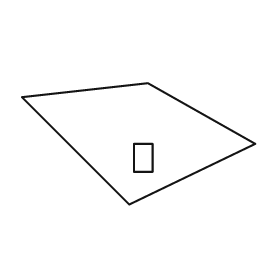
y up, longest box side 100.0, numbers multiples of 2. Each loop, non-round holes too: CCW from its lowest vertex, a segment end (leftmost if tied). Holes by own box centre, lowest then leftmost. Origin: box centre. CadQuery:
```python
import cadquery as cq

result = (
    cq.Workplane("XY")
    .moveTo(-4.0, -26.0)
    .lineTo(50.0, 0.0)
    .lineTo(4.0, 26.0)
    .lineTo(-50.0, 20.0)
    .close()
    .moveTo(-2.0, -12.0)
    .lineTo(6.0, -12.0)
    .lineTo(6.0, 0.0)
    .lineTo(-2.0, 0.0)
    .close()
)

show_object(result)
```